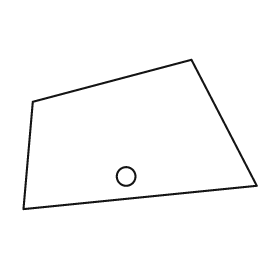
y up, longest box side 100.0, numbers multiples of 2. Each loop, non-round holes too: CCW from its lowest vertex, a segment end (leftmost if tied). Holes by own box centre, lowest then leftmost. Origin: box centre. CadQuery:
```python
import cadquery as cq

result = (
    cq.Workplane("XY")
    .moveTo(-50.0, -32.0)
    .lineTo(50.0, -22.0)
    .lineTo(22.0, 32.0)
    .lineTo(-46.0, 14.0)
    .close()
    .moveTo(-6.0, -18.0)
    .circle(4.0)
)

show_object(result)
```